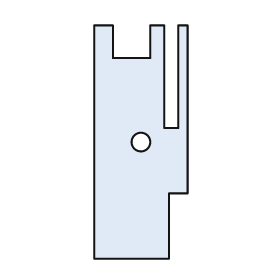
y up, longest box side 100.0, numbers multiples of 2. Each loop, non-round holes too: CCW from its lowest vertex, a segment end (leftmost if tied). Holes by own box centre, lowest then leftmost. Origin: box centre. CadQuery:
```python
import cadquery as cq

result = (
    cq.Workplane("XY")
    .moveTo(-20.0, -50.0)
    .lineTo(12.0, -50.0)
    .lineTo(12.0, -22.0)
    .lineTo(20.0, -22.0)
    .lineTo(20.0, 50.0)
    .lineTo(16.0, 50.0)
    .lineTo(16.0, 6.0)
    .lineTo(10.0, 6.0)
    .lineTo(10.0, 50.0)
    .lineTo(4.0, 50.0)
    .lineTo(4.0, 36.0)
    .lineTo(-12.0, 36.0)
    .lineTo(-12.0, 50.0)
    .lineTo(-20.0, 50.0)
    .close()
    .moveTo(0.0, 0.0)
    .circle(4.0)
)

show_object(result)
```